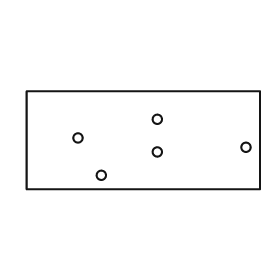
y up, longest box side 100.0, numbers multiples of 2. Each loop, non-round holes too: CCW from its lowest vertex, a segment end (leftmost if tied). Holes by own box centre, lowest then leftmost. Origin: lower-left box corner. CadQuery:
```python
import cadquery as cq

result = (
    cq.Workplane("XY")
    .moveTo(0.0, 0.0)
    .lineTo(100.0, 0.0)
    .lineTo(100.0, 42.0)
    .lineTo(0.0, 42.0)
    .close()
    .moveTo(32.0, 6.0)
    .circle(2.0)
    .moveTo(56.0, 16.0)
    .circle(2.0)
    .moveTo(94.0, 18.0)
    .circle(2.0)
    .moveTo(22.0, 22.0)
    .circle(2.0)
    .moveTo(56.0, 30.0)
    .circle(2.0)
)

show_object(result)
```